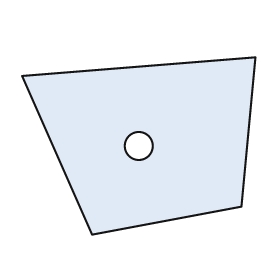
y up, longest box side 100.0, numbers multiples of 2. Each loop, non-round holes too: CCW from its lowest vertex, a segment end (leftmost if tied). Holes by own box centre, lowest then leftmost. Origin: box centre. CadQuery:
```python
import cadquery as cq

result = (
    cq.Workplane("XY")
    .moveTo(-20.0, -38.0)
    .lineTo(44.0, -26.0)
    .lineTo(50.0, 38.0)
    .lineTo(-50.0, 30.0)
    .close()
    .moveTo(0.0, 0.0)
    .circle(6.0)
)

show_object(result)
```